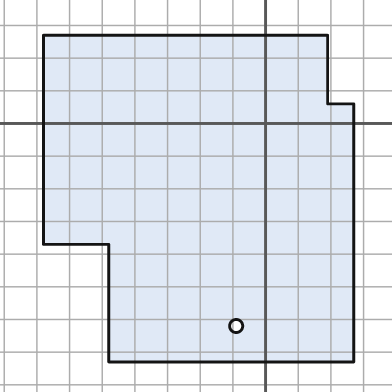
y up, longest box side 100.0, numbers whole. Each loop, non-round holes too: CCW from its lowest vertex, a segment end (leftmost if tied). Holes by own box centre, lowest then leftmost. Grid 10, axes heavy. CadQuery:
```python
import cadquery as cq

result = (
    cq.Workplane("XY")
    .moveTo(-48.0, -73.0)
    .lineTo(27.0, -73.0)
    .lineTo(27.0, 6.0)
    .lineTo(19.0, 6.0)
    .lineTo(19.0, 27.0)
    .lineTo(-68.0, 27.0)
    .lineTo(-68.0, -37.0)
    .lineTo(-48.0, -37.0)
    .close()
    .moveTo(-9.0, -62.0)
    .circle(2.0)
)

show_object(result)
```